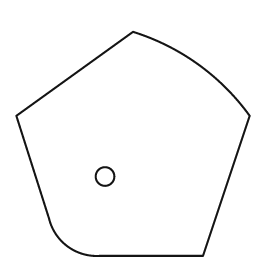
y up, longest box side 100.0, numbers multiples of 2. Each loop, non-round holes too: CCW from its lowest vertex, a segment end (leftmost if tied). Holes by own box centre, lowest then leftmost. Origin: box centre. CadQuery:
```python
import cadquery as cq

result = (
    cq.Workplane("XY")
    .moveTo(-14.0, -48.0)
    .lineTo(30.0, -48.0)
    .lineTo(50.0, 12.0)
    .threePointArc((28.0, 34.0), (0.0, 48.0))
    .lineTo(-50.0, 12.0)
    .lineTo(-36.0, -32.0)
    .threePointArc((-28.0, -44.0), (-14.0, -48.0))
    .close()
    .moveTo(-12.0, -14.0)
    .circle(4.0)
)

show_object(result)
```